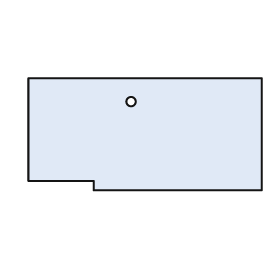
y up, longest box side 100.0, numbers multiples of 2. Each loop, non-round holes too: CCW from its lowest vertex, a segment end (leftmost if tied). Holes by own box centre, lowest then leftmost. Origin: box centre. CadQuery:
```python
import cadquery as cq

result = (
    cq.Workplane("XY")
    .moveTo(-22.0, -24.0)
    .lineTo(50.0, -24.0)
    .lineTo(50.0, 24.0)
    .lineTo(-50.0, 24.0)
    .lineTo(-50.0, -20.0)
    .lineTo(-22.0, -20.0)
    .close()
    .moveTo(-6.0, 14.0)
    .circle(2.0)
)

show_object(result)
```